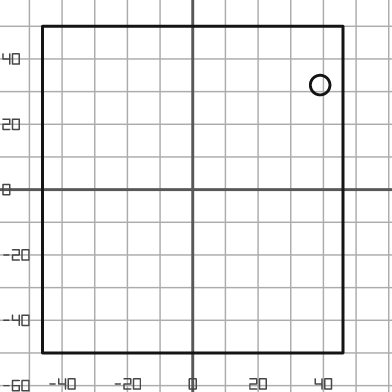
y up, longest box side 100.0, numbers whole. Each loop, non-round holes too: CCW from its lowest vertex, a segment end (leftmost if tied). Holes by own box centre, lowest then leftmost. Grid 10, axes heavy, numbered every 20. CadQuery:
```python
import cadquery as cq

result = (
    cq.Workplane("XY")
    .moveTo(-46.0, -50.0)
    .lineTo(46.0, -50.0)
    .lineTo(46.0, 50.0)
    .lineTo(-46.0, 50.0)
    .close()
    .moveTo(39.0, 32.0)
    .circle(3.0)
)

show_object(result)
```